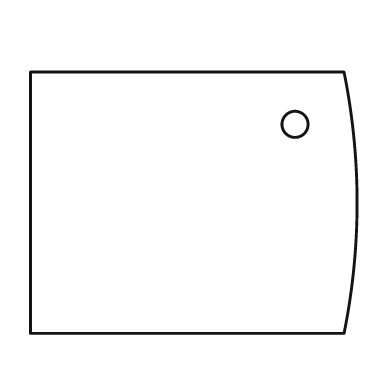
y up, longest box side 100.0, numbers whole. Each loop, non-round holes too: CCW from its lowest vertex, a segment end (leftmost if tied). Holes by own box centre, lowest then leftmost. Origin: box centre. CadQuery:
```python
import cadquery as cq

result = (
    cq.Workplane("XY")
    .moveTo(-50.0, -40.0)
    .lineTo(46.0, -40.0)
    .threePointArc((50.0, 0.0), (46.0, 40.0))
    .lineTo(-50.0, 40.0)
    .close()
    .moveTo(31.0, 24.0)
    .circle(4.0)
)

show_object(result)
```